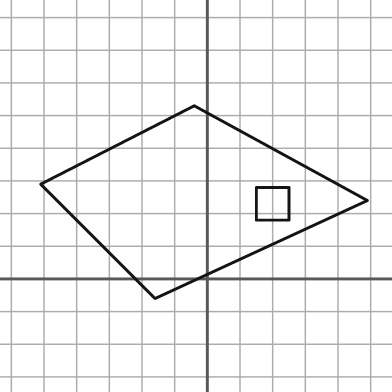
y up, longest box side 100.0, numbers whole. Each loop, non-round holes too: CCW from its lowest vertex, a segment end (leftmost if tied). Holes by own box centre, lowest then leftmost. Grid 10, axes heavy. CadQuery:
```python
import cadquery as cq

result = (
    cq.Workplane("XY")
    .moveTo(-16.0, -6.0)
    .lineTo(49.0, 24.0)
    .lineTo(-4.0, 53.0)
    .lineTo(-51.0, 29.0)
    .close()
    .moveTo(15.0, 18.0)
    .lineTo(25.0, 18.0)
    .lineTo(25.0, 28.0)
    .lineTo(15.0, 28.0)
    .close()
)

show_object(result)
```